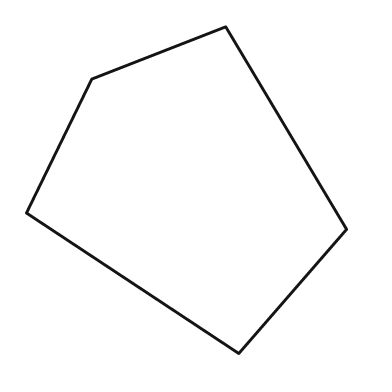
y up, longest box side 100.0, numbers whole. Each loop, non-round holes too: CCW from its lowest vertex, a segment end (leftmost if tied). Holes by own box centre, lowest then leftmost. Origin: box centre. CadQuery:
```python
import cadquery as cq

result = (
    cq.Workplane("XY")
    .moveTo(16.0, -50.0)
    .lineTo(49.0, -12.0)
    .lineTo(12.0, 50.0)
    .lineTo(-29.0, 34.0)
    .lineTo(-49.0, -7.0)
    .close()
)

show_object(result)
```